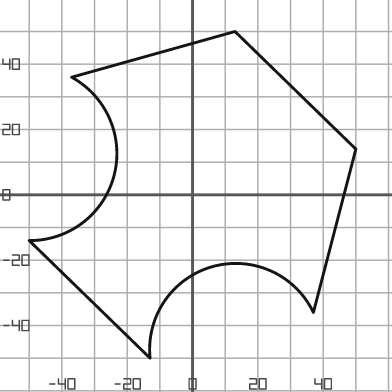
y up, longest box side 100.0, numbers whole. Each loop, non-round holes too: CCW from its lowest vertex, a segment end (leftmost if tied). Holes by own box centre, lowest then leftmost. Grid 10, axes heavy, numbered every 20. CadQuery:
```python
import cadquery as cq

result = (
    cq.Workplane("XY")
    .moveTo(-13.0, -50.0)
    .threePointArc((6.0, -22.0), (37.0, -36.0))
    .lineTo(50.0, 14.0)
    .lineTo(13.0, 50.0)
    .lineTo(-37.0, 36.0)
    .threePointArc((-24.0, 6.0), (-50.0, -14.0))
    .close()
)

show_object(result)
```